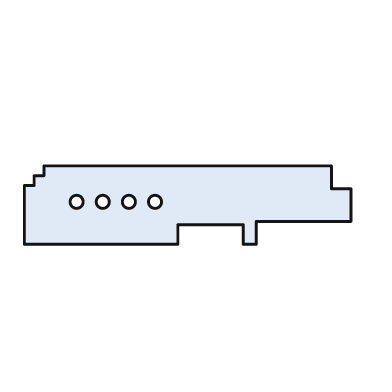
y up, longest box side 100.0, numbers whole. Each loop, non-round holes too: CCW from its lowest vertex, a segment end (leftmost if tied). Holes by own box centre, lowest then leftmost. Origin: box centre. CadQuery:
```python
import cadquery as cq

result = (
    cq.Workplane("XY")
    .moveTo(-50.0, -12.0)
    .lineTo(-3.0, -12.0)
    .lineTo(-3.0, -6.0)
    .lineTo(17.0, -6.0)
    .lineTo(17.0, -12.0)
    .lineTo(21.0, -12.0)
    .lineTo(21.0, -5.0)
    .lineTo(50.0, -5.0)
    .lineTo(50.0, 5.0)
    .lineTo(44.0, 5.0)
    .lineTo(44.0, 12.0)
    .lineTo(-44.0, 12.0)
    .lineTo(-44.0, 9.0)
    .lineTo(-47.0, 9.0)
    .lineTo(-47.0, 6.0)
    .lineTo(-50.0, 6.0)
    .close()
    .moveTo(-34.0, 1.0)
    .circle(2.0)
    .moveTo(-26.0, 1.0)
    .circle(2.0)
    .moveTo(-18.0, 1.0)
    .circle(2.0)
    .moveTo(-10.0, 1.0)
    .circle(2.0)
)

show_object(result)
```